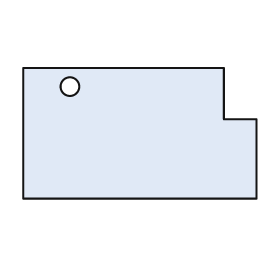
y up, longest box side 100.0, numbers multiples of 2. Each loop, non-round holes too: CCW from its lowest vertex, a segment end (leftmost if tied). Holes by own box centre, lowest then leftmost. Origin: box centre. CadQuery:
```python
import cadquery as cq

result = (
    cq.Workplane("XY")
    .moveTo(-50.0, -28.0)
    .lineTo(50.0, -28.0)
    .lineTo(50.0, 6.0)
    .lineTo(36.0, 6.0)
    .lineTo(36.0, 28.0)
    .lineTo(-50.0, 28.0)
    .close()
    .moveTo(-30.0, 20.0)
    .circle(4.0)
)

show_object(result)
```